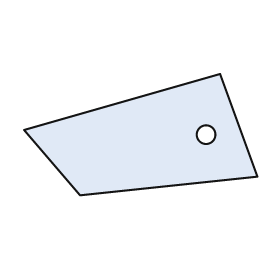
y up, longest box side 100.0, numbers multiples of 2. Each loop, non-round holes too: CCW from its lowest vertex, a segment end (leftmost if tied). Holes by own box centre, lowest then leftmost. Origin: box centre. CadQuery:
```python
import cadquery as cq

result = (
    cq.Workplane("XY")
    .moveTo(-26.0, -26.0)
    .lineTo(50.0, -18.0)
    .lineTo(34.0, 26.0)
    .lineTo(-50.0, 2.0)
    .close()
    .moveTo(28.0, 0.0)
    .circle(4.0)
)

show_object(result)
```